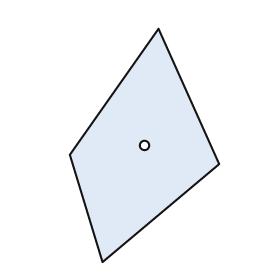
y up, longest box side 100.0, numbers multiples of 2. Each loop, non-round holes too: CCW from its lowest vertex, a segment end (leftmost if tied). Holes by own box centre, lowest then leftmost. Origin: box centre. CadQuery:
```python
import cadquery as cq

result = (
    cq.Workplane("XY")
    .moveTo(-18.0, -50.0)
    .lineTo(32.0, -8.0)
    .lineTo(6.0, 50.0)
    .lineTo(-32.0, -4.0)
    .close()
    .moveTo(0.0, 0.0)
    .circle(2.0)
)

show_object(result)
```